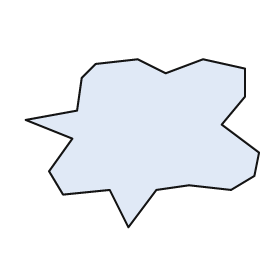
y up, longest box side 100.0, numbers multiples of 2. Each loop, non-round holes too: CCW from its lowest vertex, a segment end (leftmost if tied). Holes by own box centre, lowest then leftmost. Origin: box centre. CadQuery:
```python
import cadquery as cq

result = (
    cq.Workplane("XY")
    .moveTo(-6.0, -36.0)
    .lineTo(6.0, -20.0)
    .lineTo(20.0, -18.0)
    .lineTo(38.0, -20.0)
    .lineTo(48.0, -14.0)
    .lineTo(50.0, -4.0)
    .lineTo(34.0, 8.0)
    .lineTo(44.0, 20.0)
    .lineTo(44.0, 32.0)
    .lineTo(26.0, 36.0)
    .lineTo(10.0, 30.0)
    .lineTo(-2.0, 36.0)
    .lineTo(-20.0, 34.0)
    .lineTo(-26.0, 28.0)
    .lineTo(-28.0, 14.0)
    .lineTo(-50.0, 10.0)
    .lineTo(-30.0, 2.0)
    .lineTo(-40.0, -12.0)
    .lineTo(-34.0, -22.0)
    .lineTo(-14.0, -20.0)
    .close()
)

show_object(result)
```